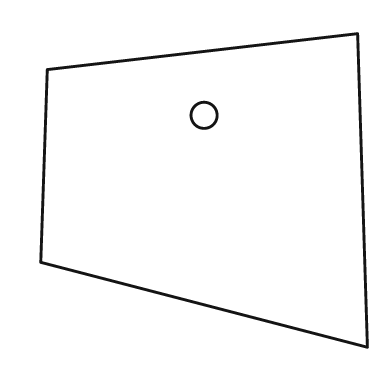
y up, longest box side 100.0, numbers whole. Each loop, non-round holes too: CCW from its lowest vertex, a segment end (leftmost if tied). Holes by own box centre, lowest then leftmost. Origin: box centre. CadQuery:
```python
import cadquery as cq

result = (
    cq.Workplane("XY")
    .moveTo(50.0, -48.0)
    .lineTo(47.0, 48.0)
    .lineTo(-48.0, 37.0)
    .lineTo(-50.0, -22.0)
    .close()
    .moveTo(0.0, 23.0)
    .circle(4.0)
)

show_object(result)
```